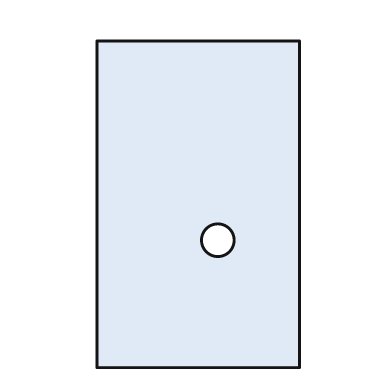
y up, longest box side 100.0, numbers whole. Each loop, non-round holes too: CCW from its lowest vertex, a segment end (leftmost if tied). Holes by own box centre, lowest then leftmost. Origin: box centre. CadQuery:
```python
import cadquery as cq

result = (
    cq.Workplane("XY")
    .moveTo(-31.0, -50.0)
    .lineTo(31.0, -50.0)
    .lineTo(31.0, 50.0)
    .lineTo(-31.0, 50.0)
    .close()
    .moveTo(6.0, -11.0)
    .circle(5.0)
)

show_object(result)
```